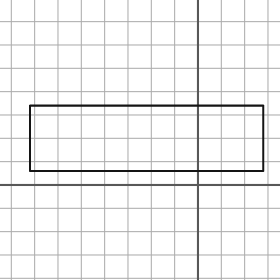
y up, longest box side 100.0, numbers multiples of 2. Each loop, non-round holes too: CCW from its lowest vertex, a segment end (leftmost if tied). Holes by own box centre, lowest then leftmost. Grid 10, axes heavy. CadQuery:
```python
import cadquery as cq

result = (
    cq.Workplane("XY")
    .moveTo(-72.0, 6.0)
    .lineTo(28.0, 6.0)
    .lineTo(28.0, 34.0)
    .lineTo(-72.0, 34.0)
    .close()
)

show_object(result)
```